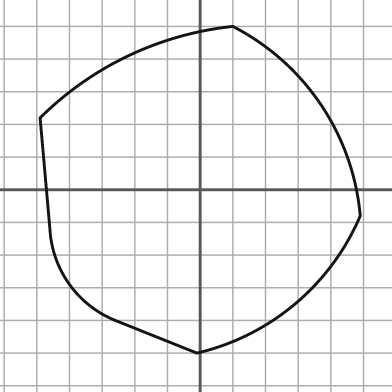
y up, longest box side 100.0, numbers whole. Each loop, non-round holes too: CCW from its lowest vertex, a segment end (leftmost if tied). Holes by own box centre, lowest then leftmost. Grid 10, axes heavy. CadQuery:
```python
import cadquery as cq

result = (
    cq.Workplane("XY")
    .moveTo(-1.0, -50.0)
    .threePointArc((29.0, -35.0), (49.0, -8.0))
    .threePointArc((37.0, 26.0), (10.0, 50.0))
    .threePointArc((-22.0, 41.0), (-49.0, 22.0))
    .lineTo(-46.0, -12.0)
    .threePointArc((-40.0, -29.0), (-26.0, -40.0))
    .close()
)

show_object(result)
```